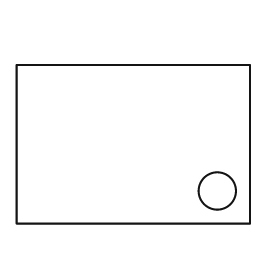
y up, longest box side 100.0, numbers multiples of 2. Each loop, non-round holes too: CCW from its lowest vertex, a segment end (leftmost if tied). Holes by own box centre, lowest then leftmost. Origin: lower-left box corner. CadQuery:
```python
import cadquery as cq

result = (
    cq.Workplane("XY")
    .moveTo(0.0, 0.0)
    .lineTo(100.0, 0.0)
    .lineTo(100.0, 68.0)
    .lineTo(0.0, 68.0)
    .close()
    .moveTo(86.0, 14.0)
    .circle(8.0)
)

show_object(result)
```